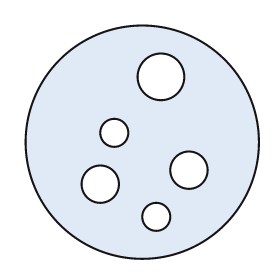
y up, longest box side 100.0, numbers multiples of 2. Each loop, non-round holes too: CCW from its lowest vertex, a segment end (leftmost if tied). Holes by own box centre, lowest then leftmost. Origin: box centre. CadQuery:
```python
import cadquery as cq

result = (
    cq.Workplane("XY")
    .moveTo(0.0, 0.0)
    .circle(50.0)
    .moveTo(6.0, -32.0)
    .circle(6.0)
    .moveTo(-18.0, -18.0)
    .circle(8.0)
    .moveTo(20.0, -12.0)
    .circle(8.0)
    .moveTo(-12.0, 4.0)
    .circle(6.0)
    .moveTo(8.0, 28.0)
    .circle(10.0)
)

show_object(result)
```